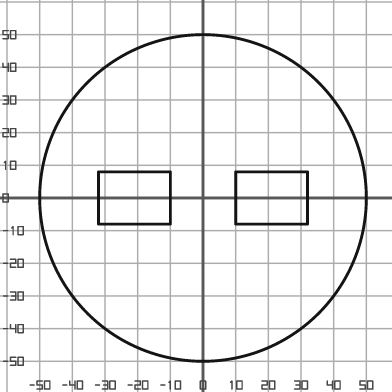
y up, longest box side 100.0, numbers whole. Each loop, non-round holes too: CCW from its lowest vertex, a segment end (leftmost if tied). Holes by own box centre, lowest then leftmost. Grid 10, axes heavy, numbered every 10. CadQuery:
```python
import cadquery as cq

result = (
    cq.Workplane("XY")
    .moveTo(0.0, 0.0)
    .circle(50.0)
    .moveTo(-32.0, -8.0)
    .lineTo(-10.0, -8.0)
    .lineTo(-10.0, 8.0)
    .lineTo(-32.0, 8.0)
    .close()
    .moveTo(10.0, -8.0)
    .lineTo(32.0, -8.0)
    .lineTo(32.0, 8.0)
    .lineTo(10.0, 8.0)
    .close()
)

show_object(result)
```